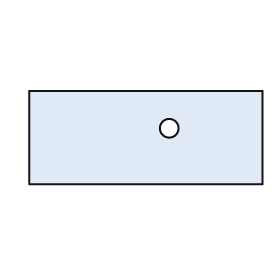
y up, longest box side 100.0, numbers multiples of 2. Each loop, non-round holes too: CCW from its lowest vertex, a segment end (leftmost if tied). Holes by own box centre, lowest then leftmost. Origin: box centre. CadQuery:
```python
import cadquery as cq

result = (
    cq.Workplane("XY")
    .moveTo(-50.0, -20.0)
    .lineTo(50.0, -20.0)
    .lineTo(50.0, 20.0)
    .lineTo(-50.0, 20.0)
    .close()
    .moveTo(10.0, 4.0)
    .circle(4.0)
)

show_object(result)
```